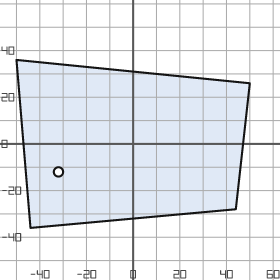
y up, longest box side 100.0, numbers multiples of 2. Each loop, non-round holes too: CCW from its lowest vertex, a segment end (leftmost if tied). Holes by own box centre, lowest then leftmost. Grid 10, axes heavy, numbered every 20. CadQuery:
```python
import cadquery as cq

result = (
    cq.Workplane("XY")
    .moveTo(-44.0, -36.0)
    .lineTo(44.0, -28.0)
    .lineTo(50.0, 26.0)
    .lineTo(-50.0, 36.0)
    .close()
    .moveTo(-32.0, -12.0)
    .circle(2.0)
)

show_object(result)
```